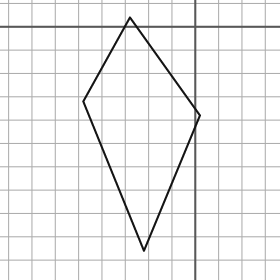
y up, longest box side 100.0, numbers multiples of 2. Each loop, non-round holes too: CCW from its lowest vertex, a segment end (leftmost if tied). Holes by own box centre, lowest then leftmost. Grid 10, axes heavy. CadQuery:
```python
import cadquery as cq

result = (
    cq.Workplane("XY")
    .moveTo(-22.0, -96.0)
    .lineTo(2.0, -38.0)
    .lineTo(-28.0, 4.0)
    .lineTo(-48.0, -32.0)
    .close()
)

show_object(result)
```